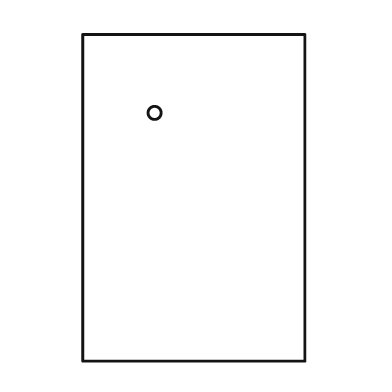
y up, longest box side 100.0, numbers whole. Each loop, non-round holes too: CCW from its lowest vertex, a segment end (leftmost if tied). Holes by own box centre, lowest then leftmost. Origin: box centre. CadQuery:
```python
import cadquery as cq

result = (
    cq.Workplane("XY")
    .moveTo(-34.0, -50.0)
    .lineTo(34.0, -50.0)
    .lineTo(34.0, 50.0)
    .lineTo(-34.0, 50.0)
    .close()
    .moveTo(-12.0, 26.0)
    .circle(2.0)
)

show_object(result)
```